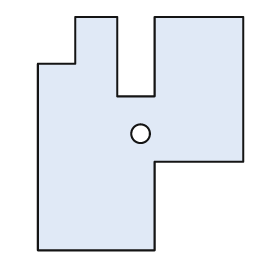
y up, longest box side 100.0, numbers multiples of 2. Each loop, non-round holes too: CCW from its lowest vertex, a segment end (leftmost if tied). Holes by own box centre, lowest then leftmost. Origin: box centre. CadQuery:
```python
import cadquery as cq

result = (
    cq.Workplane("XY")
    .moveTo(-44.0, -50.0)
    .lineTo(6.0, -50.0)
    .lineTo(6.0, -12.0)
    .lineTo(44.0, -12.0)
    .lineTo(44.0, 50.0)
    .lineTo(6.0, 50.0)
    .lineTo(6.0, 16.0)
    .lineTo(-10.0, 16.0)
    .lineTo(-10.0, 50.0)
    .lineTo(-28.0, 50.0)
    .lineTo(-28.0, 30.0)
    .lineTo(-44.0, 30.0)
    .close()
    .moveTo(0.0, 0.0)
    .circle(4.0)
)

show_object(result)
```